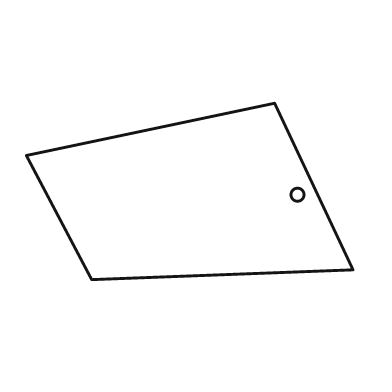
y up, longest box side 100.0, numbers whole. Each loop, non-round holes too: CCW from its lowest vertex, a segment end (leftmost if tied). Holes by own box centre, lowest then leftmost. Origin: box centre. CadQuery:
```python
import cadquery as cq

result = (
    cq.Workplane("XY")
    .moveTo(-30.0, -27.0)
    .lineTo(50.0, -24.0)
    .lineTo(26.0, 27.0)
    .lineTo(-50.0, 11.0)
    .close()
    .moveTo(33.0, -1.0)
    .circle(2.0)
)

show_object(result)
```